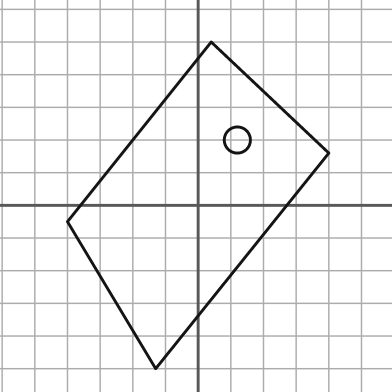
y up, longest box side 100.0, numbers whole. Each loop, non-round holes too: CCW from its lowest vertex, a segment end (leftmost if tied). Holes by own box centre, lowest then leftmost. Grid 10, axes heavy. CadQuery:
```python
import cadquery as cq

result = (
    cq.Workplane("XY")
    .moveTo(-13.0, -50.0)
    .lineTo(40.0, 16.0)
    .lineTo(4.0, 50.0)
    .lineTo(-40.0, -5.0)
    .close()
    .moveTo(12.0, 20.0)
    .circle(4.0)
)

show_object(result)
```